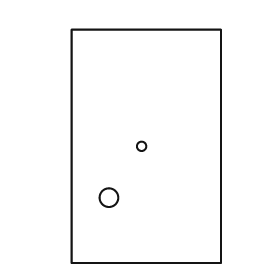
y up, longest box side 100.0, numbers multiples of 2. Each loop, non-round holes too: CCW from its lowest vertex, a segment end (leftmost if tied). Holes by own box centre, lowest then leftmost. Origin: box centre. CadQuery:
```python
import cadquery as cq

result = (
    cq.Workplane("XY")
    .moveTo(-32.0, -50.0)
    .lineTo(32.0, -50.0)
    .lineTo(32.0, 50.0)
    .lineTo(-32.0, 50.0)
    .close()
    .moveTo(-16.0, -22.0)
    .circle(4.0)
    .moveTo(-2.0, 0.0)
    .circle(2.0)
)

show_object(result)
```